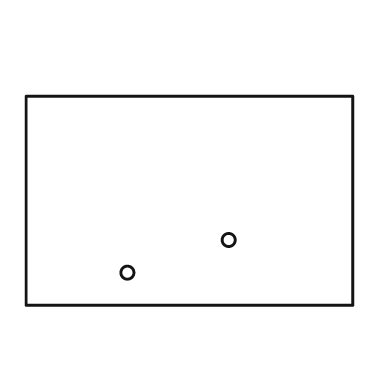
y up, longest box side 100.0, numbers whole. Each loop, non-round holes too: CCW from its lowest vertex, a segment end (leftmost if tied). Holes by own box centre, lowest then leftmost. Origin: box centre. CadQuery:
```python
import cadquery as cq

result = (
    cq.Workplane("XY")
    .moveTo(-50.0, -32.0)
    .lineTo(50.0, -32.0)
    .lineTo(50.0, 32.0)
    .lineTo(-50.0, 32.0)
    .close()
    .moveTo(-19.0, -22.0)
    .circle(2.0)
    .moveTo(12.0, -12.0)
    .circle(2.0)
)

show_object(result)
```